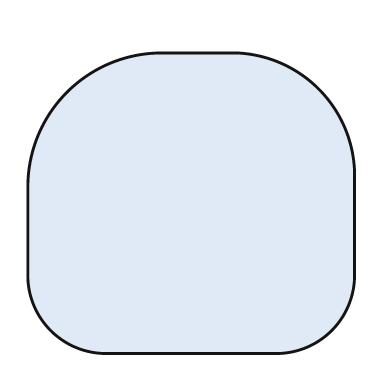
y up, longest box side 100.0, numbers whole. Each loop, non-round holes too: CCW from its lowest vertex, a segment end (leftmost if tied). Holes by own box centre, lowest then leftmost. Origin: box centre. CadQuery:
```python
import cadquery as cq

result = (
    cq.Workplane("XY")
    .moveTo(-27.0, -46.0)
    .lineTo(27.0, -46.0)
    .threePointArc((43.0, -39.0), (50.0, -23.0))
    .lineTo(50.0, 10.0)
    .threePointArc((39.0, 35.0), (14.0, 46.0))
    .lineTo(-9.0, 46.0)
    .threePointArc((-38.0, 34.0), (-50.0, 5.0))
    .lineTo(-50.0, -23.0)
    .threePointArc((-43.0, -39.0), (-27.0, -46.0))
    .close()
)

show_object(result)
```